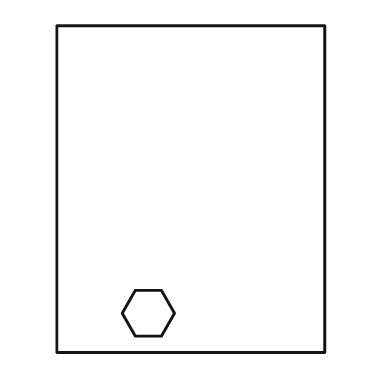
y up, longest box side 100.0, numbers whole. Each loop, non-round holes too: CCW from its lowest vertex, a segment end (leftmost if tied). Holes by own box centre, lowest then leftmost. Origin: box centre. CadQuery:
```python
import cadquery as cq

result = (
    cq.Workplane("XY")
    .moveTo(-41.0, -50.0)
    .lineTo(41.0, -50.0)
    .lineTo(41.0, 50.0)
    .lineTo(-41.0, 50.0)
    .close()
    .moveTo(-17.0, -45.0)
    .lineTo(-9.0, -45.0)
    .lineTo(-5.0, -38.0)
    .lineTo(-9.0, -31.0)
    .lineTo(-17.0, -31.0)
    .lineTo(-21.0, -38.0)
    .close()
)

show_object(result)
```